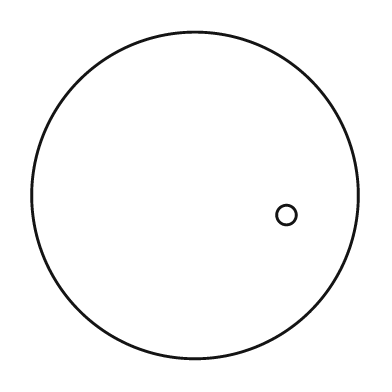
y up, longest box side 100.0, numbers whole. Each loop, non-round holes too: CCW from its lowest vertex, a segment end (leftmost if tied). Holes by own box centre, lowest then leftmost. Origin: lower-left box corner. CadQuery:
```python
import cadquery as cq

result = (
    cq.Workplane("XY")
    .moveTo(50.0, 50.0)
    .circle(50.0)
    .moveTo(78.0, 44.0)
    .circle(3.0)
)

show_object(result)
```